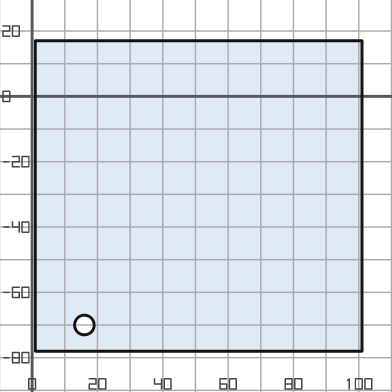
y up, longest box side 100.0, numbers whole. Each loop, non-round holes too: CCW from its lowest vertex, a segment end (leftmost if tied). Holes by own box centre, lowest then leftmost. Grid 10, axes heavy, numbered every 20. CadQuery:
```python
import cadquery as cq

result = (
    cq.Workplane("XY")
    .moveTo(1.0, -78.0)
    .lineTo(101.0, -78.0)
    .lineTo(101.0, 17.0)
    .lineTo(1.0, 17.0)
    .close()
    .moveTo(16.0, -70.0)
    .circle(3.0)
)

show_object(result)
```